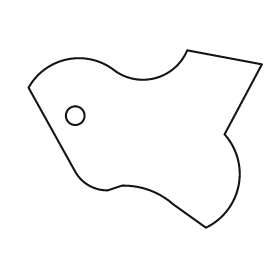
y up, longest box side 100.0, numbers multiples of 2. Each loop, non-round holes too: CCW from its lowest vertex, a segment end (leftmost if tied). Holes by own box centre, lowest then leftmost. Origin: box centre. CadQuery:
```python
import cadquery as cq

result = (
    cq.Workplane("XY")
    .moveTo(26.0, -38.0)
    .threePointArc((40.0, -20.0), (34.0, 2.0))
    .lineTo(50.0, 32.0)
    .lineTo(18.0, 38.0)
    .threePointArc((4.0, 26.0), (-14.0, 30.0))
    .threePointArc((-34.0, 34.0), (-50.0, 22.0))
    .lineTo(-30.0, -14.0)
    .threePointArc((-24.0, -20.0), (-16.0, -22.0))
    .lineTo(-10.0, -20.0)
    .threePointArc((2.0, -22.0), (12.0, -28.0))
    .close()
    .moveTo(-30.0, 10.0)
    .circle(4.0)
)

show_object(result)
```